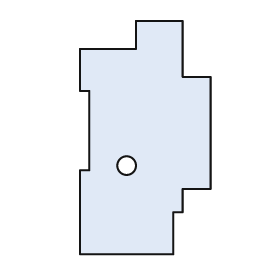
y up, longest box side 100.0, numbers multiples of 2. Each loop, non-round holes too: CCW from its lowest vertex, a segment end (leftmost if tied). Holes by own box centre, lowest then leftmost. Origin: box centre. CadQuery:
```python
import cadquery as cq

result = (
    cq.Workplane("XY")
    .moveTo(-28.0, -50.0)
    .lineTo(12.0, -50.0)
    .lineTo(12.0, -32.0)
    .lineTo(16.0, -32.0)
    .lineTo(16.0, -22.0)
    .lineTo(28.0, -22.0)
    .lineTo(28.0, 26.0)
    .lineTo(16.0, 26.0)
    .lineTo(16.0, 50.0)
    .lineTo(-4.0, 50.0)
    .lineTo(-4.0, 38.0)
    .lineTo(-28.0, 38.0)
    .lineTo(-28.0, 20.0)
    .lineTo(-24.0, 20.0)
    .lineTo(-24.0, -14.0)
    .lineTo(-28.0, -14.0)
    .close()
    .moveTo(-8.0, -12.0)
    .circle(4.0)
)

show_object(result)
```